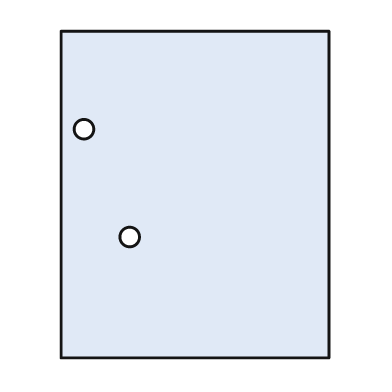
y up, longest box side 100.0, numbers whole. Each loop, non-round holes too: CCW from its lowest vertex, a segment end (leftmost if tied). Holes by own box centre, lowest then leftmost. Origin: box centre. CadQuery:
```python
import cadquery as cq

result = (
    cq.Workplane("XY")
    .moveTo(-41.0, -50.0)
    .lineTo(41.0, -50.0)
    .lineTo(41.0, 50.0)
    .lineTo(-41.0, 50.0)
    .close()
    .moveTo(-20.0, -13.0)
    .circle(3.0)
    .moveTo(-34.0, 20.0)
    .circle(3.0)
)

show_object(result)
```